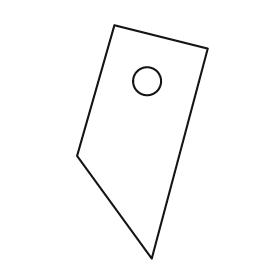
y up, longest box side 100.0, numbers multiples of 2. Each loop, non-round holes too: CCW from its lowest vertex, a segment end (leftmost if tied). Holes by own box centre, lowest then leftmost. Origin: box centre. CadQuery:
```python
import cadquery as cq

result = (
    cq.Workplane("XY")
    .moveTo(4.0, -50.0)
    .lineTo(28.0, 40.0)
    .lineTo(-12.0, 50.0)
    .lineTo(-28.0, -6.0)
    .close()
    .moveTo(2.0, 26.0)
    .circle(6.0)
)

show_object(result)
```